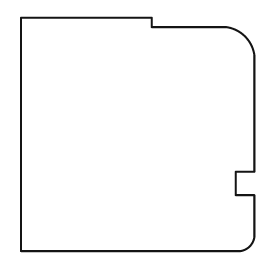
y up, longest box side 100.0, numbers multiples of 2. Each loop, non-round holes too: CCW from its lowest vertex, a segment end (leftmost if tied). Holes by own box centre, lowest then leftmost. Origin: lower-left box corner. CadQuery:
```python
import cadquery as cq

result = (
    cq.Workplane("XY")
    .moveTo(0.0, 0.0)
    .lineTo(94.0, 0.0)
    .threePointArc((98.0, 2.0), (100.0, 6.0))
    .lineTo(100.0, 24.0)
    .lineTo(92.0, 24.0)
    .lineTo(92.0, 34.0)
    .lineTo(100.0, 34.0)
    .lineTo(100.0, 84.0)
    .threePointArc((96.0, 92.0), (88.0, 96.0))
    .lineTo(56.0, 96.0)
    .lineTo(56.0, 100.0)
    .lineTo(0.0, 100.0)
    .close()
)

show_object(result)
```